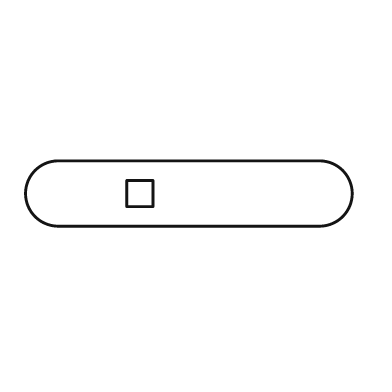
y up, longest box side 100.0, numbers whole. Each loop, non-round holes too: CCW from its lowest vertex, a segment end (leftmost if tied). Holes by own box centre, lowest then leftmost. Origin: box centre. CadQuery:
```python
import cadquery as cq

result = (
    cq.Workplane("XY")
    .moveTo(-40.0, -10.0)
    .lineTo(40.0, -10.0)
    .threePointArc((50.0, 0.0), (40.0, 10.0))
    .lineTo(-40.0, 10.0)
    .threePointArc((-50.0, 0.0), (-40.0, -10.0))
    .close()
    .moveTo(-19.0, -4.0)
    .lineTo(-11.0, -4.0)
    .lineTo(-11.0, 4.0)
    .lineTo(-19.0, 4.0)
    .close()
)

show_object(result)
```